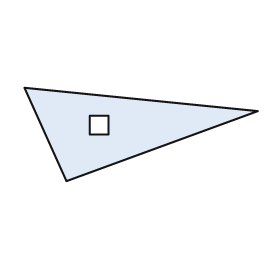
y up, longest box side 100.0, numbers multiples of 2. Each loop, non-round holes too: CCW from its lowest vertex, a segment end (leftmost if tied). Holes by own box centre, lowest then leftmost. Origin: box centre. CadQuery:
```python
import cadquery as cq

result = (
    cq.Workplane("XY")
    .moveTo(-32.0, -20.0)
    .lineTo(50.0, 10.0)
    .lineTo(-50.0, 20.0)
    .close()
    .moveTo(-22.0, 0.0)
    .lineTo(-14.0, 0.0)
    .lineTo(-14.0, 8.0)
    .lineTo(-22.0, 8.0)
    .close()
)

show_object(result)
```